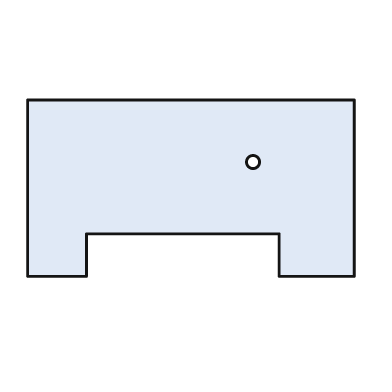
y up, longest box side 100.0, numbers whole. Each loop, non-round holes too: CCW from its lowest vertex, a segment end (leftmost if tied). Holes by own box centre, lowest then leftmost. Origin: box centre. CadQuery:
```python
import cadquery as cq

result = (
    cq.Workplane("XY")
    .moveTo(-50.0, -27.0)
    .lineTo(-32.0, -27.0)
    .lineTo(-32.0, -14.0)
    .lineTo(27.0, -14.0)
    .lineTo(27.0, -27.0)
    .lineTo(50.0, -27.0)
    .lineTo(50.0, 27.0)
    .lineTo(-50.0, 27.0)
    .close()
    .moveTo(19.0, 8.0)
    .circle(2.0)
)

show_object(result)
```